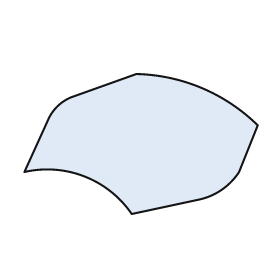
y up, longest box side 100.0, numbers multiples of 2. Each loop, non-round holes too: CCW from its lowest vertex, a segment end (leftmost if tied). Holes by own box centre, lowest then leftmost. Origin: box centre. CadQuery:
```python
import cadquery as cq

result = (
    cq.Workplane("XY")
    .moveTo(-4.0, -30.0)
    .lineTo(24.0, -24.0)
    .threePointArc((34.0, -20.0), (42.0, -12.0))
    .lineTo(50.0, 8.0)
    .threePointArc((26.0, 24.0), (-2.0, 30.0))
    .lineTo(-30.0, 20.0)
    .threePointArc((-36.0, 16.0), (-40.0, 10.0))
    .lineTo(-50.0, -12.0)
    .threePointArc((-24.0, -14.0), (-4.0, -30.0))
    .close()
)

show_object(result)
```